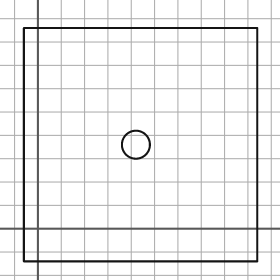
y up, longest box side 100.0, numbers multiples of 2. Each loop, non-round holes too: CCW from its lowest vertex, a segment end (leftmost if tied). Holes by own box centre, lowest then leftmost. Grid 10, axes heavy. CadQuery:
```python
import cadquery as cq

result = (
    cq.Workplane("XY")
    .moveTo(-6.0, -14.0)
    .lineTo(94.0, -14.0)
    .lineTo(94.0, 86.0)
    .lineTo(-6.0, 86.0)
    .close()
    .moveTo(42.0, 36.0)
    .circle(6.0)
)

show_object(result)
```